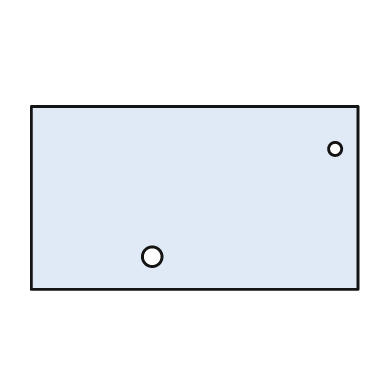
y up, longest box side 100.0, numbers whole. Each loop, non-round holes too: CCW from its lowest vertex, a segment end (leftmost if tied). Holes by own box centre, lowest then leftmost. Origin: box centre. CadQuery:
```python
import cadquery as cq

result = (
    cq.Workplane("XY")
    .moveTo(-50.0, -28.0)
    .lineTo(50.0, -28.0)
    .lineTo(50.0, 28.0)
    .lineTo(-50.0, 28.0)
    .close()
    .moveTo(-13.0, -18.0)
    .circle(3.0)
    .moveTo(43.0, 15.0)
    .circle(2.0)
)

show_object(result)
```